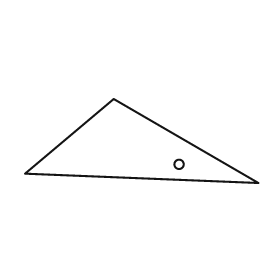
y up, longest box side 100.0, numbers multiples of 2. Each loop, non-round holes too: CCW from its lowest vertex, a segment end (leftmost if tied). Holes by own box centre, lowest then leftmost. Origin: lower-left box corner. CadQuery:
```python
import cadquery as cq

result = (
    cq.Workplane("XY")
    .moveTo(100.0, 0.0)
    .lineTo(38.0, 36.0)
    .lineTo(0.0, 4.0)
    .close()
    .moveTo(66.0, 8.0)
    .circle(2.0)
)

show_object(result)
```